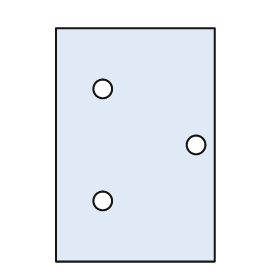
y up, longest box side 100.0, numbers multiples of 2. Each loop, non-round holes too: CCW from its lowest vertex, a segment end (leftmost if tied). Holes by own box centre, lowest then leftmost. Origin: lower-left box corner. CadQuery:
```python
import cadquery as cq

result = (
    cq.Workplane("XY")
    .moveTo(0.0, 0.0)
    .lineTo(68.0, 0.0)
    .lineTo(68.0, 100.0)
    .lineTo(0.0, 100.0)
    .close()
    .moveTo(20.0, 26.0)
    .circle(4.0)
    .moveTo(60.0, 50.0)
    .circle(4.0)
    .moveTo(20.0, 74.0)
    .circle(4.0)
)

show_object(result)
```